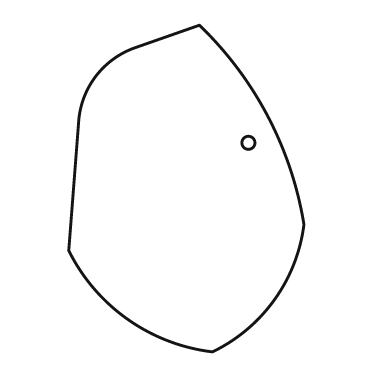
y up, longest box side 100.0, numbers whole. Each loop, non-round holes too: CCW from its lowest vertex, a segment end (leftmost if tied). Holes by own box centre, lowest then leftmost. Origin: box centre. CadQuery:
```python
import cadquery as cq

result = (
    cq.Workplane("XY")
    .moveTo(8.0, -50.0)
    .threePointArc((27.0, -34.0), (36.0, -11.0))
    .threePointArc((25.0, 22.0), (4.0, 50.0))
    .lineTo(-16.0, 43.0)
    .threePointArc((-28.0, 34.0), (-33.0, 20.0))
    .lineTo(-36.0, -19.0)
    .threePointArc((-18.0, -40.0), (8.0, -50.0))
    .close()
    .moveTo(19.0, 14.0)
    .circle(2.0)
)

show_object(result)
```